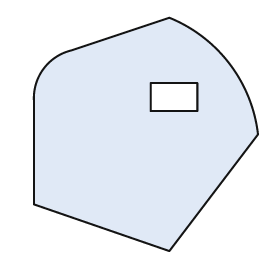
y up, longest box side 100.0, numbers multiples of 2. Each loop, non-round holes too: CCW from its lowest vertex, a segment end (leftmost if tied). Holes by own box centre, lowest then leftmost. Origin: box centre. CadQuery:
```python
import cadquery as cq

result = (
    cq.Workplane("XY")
    .moveTo(10.0, -50.0)
    .lineTo(48.0, 0.0)
    .threePointArc((36.0, 30.0), (10.0, 50.0))
    .lineTo(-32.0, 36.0)
    .threePointArc((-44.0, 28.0), (-48.0, 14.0))
    .lineTo(-48.0, -30.0)
    .close()
    .moveTo(2.0, 10.0)
    .lineTo(22.0, 10.0)
    .lineTo(22.0, 22.0)
    .lineTo(2.0, 22.0)
    .close()
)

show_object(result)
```